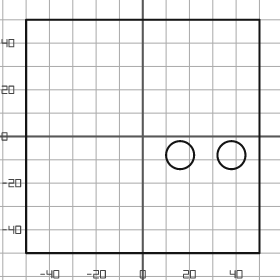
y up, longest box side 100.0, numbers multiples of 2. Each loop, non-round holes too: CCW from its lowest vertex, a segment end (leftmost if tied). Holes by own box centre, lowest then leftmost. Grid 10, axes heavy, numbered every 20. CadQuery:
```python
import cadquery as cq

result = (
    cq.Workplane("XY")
    .moveTo(-50.0, -50.0)
    .lineTo(50.0, -50.0)
    .lineTo(50.0, 50.0)
    .lineTo(-50.0, 50.0)
    .close()
    .moveTo(16.0, -8.0)
    .circle(6.0)
    .moveTo(38.0, -8.0)
    .circle(6.0)
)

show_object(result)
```